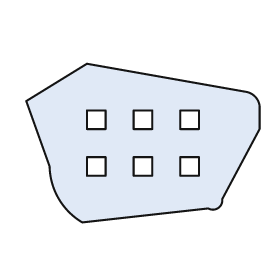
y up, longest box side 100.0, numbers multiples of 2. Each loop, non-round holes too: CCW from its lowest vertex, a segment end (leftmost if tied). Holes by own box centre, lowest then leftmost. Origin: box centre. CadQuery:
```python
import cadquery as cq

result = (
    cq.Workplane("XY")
    .moveTo(-26.0, -34.0)
    .lineTo(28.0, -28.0)
    .threePointArc((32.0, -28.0), (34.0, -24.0))
    .lineTo(50.0, 6.0)
    .lineTo(50.0, 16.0)
    .threePointArc((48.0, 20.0), (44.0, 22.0))
    .lineTo(-24.0, 34.0)
    .lineTo(-50.0, 18.0)
    .lineTo(-40.0, -10.0)
    .threePointArc((-36.0, -24.0), (-26.0, -34.0))
    .close()
    .moveTo(-24.0, -14.0)
    .lineTo(-16.0, -14.0)
    .lineTo(-16.0, -6.0)
    .lineTo(-24.0, -6.0)
    .close()
    .moveTo(-4.0, -14.0)
    .lineTo(4.0, -14.0)
    .lineTo(4.0, -6.0)
    .lineTo(-4.0, -6.0)
    .close()
    .moveTo(16.0, -14.0)
    .lineTo(24.0, -14.0)
    .lineTo(24.0, -6.0)
    .lineTo(16.0, -6.0)
    .close()
    .moveTo(-24.0, 6.0)
    .lineTo(-16.0, 6.0)
    .lineTo(-16.0, 14.0)
    .lineTo(-24.0, 14.0)
    .close()
    .moveTo(-4.0, 6.0)
    .lineTo(4.0, 6.0)
    .lineTo(4.0, 14.0)
    .lineTo(-4.0, 14.0)
    .close()
    .moveTo(16.0, 6.0)
    .lineTo(24.0, 6.0)
    .lineTo(24.0, 14.0)
    .lineTo(16.0, 14.0)
    .close()
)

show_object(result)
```